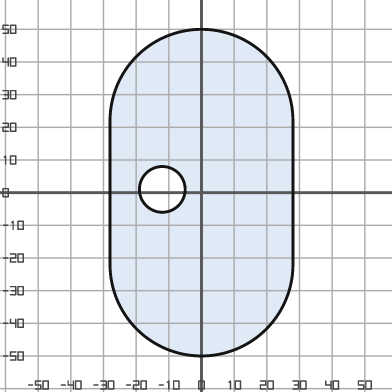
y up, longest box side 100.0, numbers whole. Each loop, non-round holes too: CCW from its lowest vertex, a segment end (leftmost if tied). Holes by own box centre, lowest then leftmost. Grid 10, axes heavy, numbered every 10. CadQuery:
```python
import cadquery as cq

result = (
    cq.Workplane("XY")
    .moveTo(-28.0, -22.0)
    .threePointArc((0.0, -50.0), (28.0, -22.0))
    .lineTo(28.0, 22.0)
    .threePointArc((0.0, 50.0), (-28.0, 22.0))
    .close()
    .moveTo(-12.0, 1.0)
    .circle(7.0)
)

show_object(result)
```